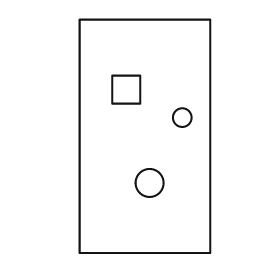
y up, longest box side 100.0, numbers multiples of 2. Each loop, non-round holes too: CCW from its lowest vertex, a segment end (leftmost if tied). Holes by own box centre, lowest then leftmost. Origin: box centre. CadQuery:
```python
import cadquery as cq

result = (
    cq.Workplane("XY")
    .moveTo(-28.0, -50.0)
    .lineTo(28.0, -50.0)
    .lineTo(28.0, 50.0)
    .lineTo(-28.0, 50.0)
    .close()
    .moveTo(2.0, -20.0)
    .circle(6.0)
    .moveTo(16.0, 8.0)
    .circle(4.0)
    .moveTo(-14.0, 14.0)
    .lineTo(-2.0, 14.0)
    .lineTo(-2.0, 26.0)
    .lineTo(-14.0, 26.0)
    .close()
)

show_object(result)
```